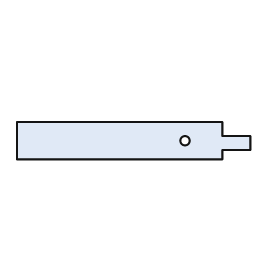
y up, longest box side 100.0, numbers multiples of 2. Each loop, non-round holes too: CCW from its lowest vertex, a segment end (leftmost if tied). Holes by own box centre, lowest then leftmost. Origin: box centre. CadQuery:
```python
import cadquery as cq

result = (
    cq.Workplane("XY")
    .moveTo(-50.0, -8.0)
    .lineTo(38.0, -8.0)
    .lineTo(38.0, -4.0)
    .lineTo(50.0, -4.0)
    .lineTo(50.0, 2.0)
    .lineTo(38.0, 2.0)
    .lineTo(38.0, 8.0)
    .lineTo(-50.0, 8.0)
    .close()
    .moveTo(22.0, 0.0)
    .circle(2.0)
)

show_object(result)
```